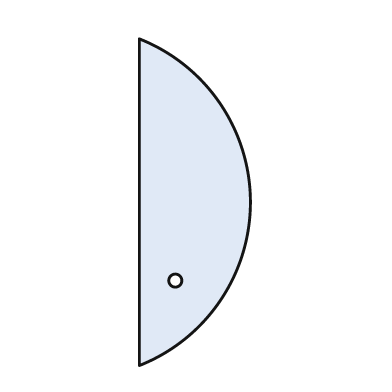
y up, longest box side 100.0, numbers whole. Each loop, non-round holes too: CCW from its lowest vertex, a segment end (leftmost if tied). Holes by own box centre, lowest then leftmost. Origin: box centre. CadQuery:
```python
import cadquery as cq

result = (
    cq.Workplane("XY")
    .moveTo(-17.0, -50.0)
    .threePointArc((17.0, 0.0), (-17.0, 50.0))
    .close()
    .moveTo(-6.0, -24.0)
    .circle(2.0)
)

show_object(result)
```